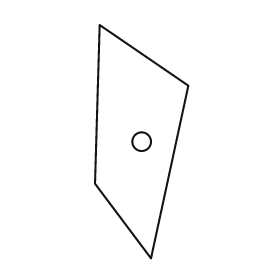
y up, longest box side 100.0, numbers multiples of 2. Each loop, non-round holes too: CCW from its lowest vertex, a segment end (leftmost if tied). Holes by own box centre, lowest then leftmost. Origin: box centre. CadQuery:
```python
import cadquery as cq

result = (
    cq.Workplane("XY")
    .moveTo(4.0, -50.0)
    .lineTo(20.0, 24.0)
    .lineTo(-18.0, 50.0)
    .lineTo(-20.0, -18.0)
    .close()
    .moveTo(0.0, 0.0)
    .circle(4.0)
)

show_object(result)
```